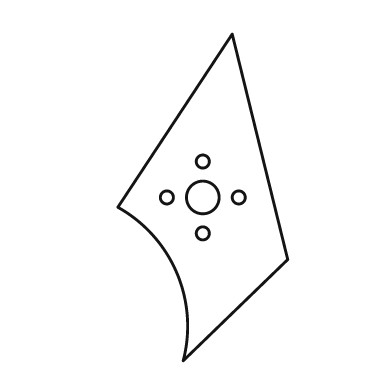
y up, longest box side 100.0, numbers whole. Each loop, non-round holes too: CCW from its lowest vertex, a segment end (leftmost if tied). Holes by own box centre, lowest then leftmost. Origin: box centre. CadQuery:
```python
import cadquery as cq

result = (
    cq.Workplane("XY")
    .moveTo(-6.0, -50.0)
    .lineTo(26.0, -19.0)
    .lineTo(9.0, 50.0)
    .lineTo(-26.0, -3.0)
    .threePointArc((-8.0, -23.0), (-6.0, -50.0))
    .close()
    .moveTo(0.0, -11.0)
    .circle(2.0)
    .moveTo(-11.0, 0.0)
    .circle(2.0)
    .moveTo(0.0, 0.0)
    .circle(5.0)
    .moveTo(11.0, 0.0)
    .circle(2.0)
    .moveTo(0.0, 11.0)
    .circle(2.0)
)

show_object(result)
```